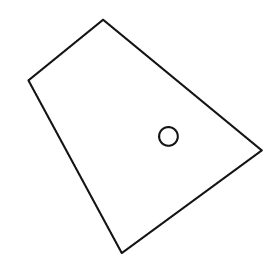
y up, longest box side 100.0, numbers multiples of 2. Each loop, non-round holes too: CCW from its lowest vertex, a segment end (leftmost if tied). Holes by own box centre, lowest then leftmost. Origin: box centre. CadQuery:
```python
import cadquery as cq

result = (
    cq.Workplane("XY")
    .moveTo(-10.0, -50.0)
    .lineTo(50.0, -6.0)
    .lineTo(-18.0, 50.0)
    .lineTo(-50.0, 24.0)
    .close()
    .moveTo(10.0, 0.0)
    .circle(4.0)
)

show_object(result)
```